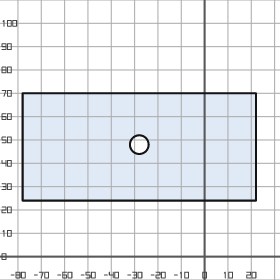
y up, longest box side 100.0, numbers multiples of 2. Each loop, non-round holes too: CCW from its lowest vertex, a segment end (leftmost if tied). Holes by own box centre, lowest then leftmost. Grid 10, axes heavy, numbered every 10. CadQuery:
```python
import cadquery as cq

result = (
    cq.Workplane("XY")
    .moveTo(-78.0, 24.0)
    .lineTo(22.0, 24.0)
    .lineTo(22.0, 70.0)
    .lineTo(-78.0, 70.0)
    .close()
    .moveTo(-28.0, 48.0)
    .circle(4.0)
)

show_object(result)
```